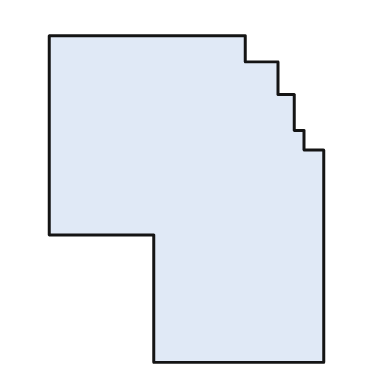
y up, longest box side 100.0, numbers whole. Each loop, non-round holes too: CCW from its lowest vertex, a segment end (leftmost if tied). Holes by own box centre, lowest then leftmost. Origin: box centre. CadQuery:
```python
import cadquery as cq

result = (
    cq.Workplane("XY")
    .moveTo(-10.0, -50.0)
    .lineTo(42.0, -50.0)
    .lineTo(42.0, 15.0)
    .lineTo(36.0, 15.0)
    .lineTo(36.0, 21.0)
    .lineTo(33.0, 21.0)
    .lineTo(33.0, 32.0)
    .lineTo(28.0, 32.0)
    .lineTo(28.0, 42.0)
    .lineTo(18.0, 42.0)
    .lineTo(18.0, 50.0)
    .lineTo(-42.0, 50.0)
    .lineTo(-42.0, -11.0)
    .lineTo(-10.0, -11.0)
    .close()
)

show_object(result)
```